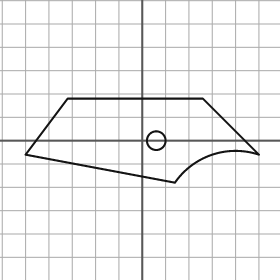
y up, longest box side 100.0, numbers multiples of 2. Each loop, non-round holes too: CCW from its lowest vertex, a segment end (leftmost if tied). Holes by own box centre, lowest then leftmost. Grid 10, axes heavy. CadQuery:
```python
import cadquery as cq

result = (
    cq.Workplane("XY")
    .moveTo(14.0, -18.0)
    .threePointArc((30.0, -6.0), (50.0, -6.0))
    .lineTo(26.0, 18.0)
    .lineTo(-32.0, 18.0)
    .lineTo(-50.0, -6.0)
    .close()
    .moveTo(6.0, 0.0)
    .circle(4.0)
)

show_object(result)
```